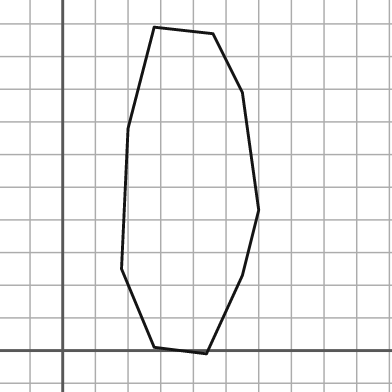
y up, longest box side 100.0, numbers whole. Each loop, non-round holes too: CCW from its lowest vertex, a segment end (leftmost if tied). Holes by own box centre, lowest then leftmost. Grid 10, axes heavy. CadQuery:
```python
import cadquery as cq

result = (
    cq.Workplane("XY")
    .moveTo(44.0, -1.0)
    .lineTo(55.0, 23.0)
    .lineTo(60.0, 43.0)
    .lineTo(55.0, 79.0)
    .lineTo(46.0, 97.0)
    .lineTo(28.0, 99.0)
    .lineTo(20.0, 68.0)
    .lineTo(18.0, 25.0)
    .lineTo(28.0, 1.0)
    .close()
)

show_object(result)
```